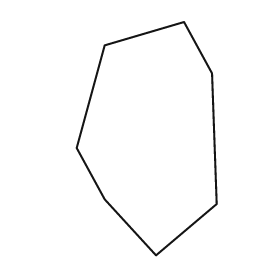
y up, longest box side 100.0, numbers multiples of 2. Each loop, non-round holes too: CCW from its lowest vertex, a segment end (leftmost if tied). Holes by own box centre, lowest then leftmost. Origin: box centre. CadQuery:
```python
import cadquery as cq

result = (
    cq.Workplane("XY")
    .moveTo(4.0, -50.0)
    .lineTo(30.0, -28.0)
    .lineTo(28.0, 28.0)
    .lineTo(16.0, 50.0)
    .lineTo(-18.0, 40.0)
    .lineTo(-30.0, -4.0)
    .lineTo(-18.0, -26.0)
    .close()
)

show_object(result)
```